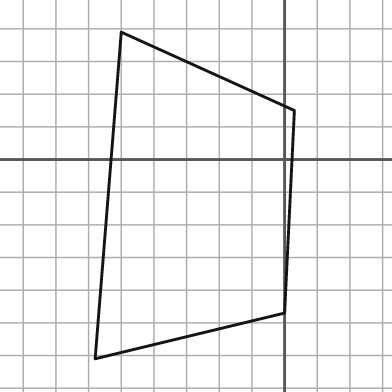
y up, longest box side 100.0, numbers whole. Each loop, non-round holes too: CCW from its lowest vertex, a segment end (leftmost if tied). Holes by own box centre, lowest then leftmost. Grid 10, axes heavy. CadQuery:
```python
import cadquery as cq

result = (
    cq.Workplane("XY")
    .moveTo(-58.0, -61.0)
    .lineTo(0.0, -47.0)
    .lineTo(3.0, 15.0)
    .lineTo(-50.0, 39.0)
    .close()
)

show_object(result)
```